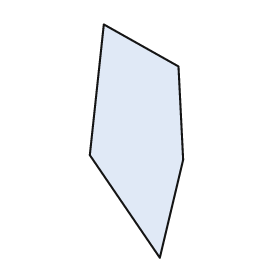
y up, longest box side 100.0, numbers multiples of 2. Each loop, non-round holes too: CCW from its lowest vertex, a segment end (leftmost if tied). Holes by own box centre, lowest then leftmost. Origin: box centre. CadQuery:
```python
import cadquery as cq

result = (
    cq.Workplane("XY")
    .moveTo(10.0, -50.0)
    .lineTo(20.0, -8.0)
    .lineTo(18.0, 32.0)
    .lineTo(-14.0, 50.0)
    .lineTo(-20.0, -6.0)
    .close()
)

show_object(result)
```